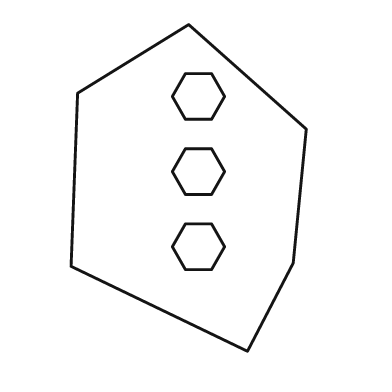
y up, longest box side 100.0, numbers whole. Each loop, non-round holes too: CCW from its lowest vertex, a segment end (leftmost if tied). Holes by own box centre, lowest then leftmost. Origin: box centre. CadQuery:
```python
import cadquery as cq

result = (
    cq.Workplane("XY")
    .moveTo(18.0, -50.0)
    .lineTo(32.0, -23.0)
    .lineTo(36.0, 18.0)
    .lineTo(0.0, 50.0)
    .lineTo(-34.0, 29.0)
    .lineTo(-36.0, -24.0)
    .close()
    .moveTo(-1.0, -25.0)
    .lineTo(7.0, -25.0)
    .lineTo(11.0, -18.0)
    .lineTo(7.0, -11.0)
    .lineTo(-1.0, -11.0)
    .lineTo(-5.0, -18.0)
    .close()
    .moveTo(-1.0, -2.0)
    .lineTo(7.0, -2.0)
    .lineTo(11.0, 5.0)
    .lineTo(7.0, 12.0)
    .lineTo(-1.0, 12.0)
    .lineTo(-5.0, 5.0)
    .close()
    .moveTo(-1.0, 21.0)
    .lineTo(7.0, 21.0)
    .lineTo(11.0, 28.0)
    .lineTo(7.0, 35.0)
    .lineTo(-1.0, 35.0)
    .lineTo(-5.0, 28.0)
    .close()
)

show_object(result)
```